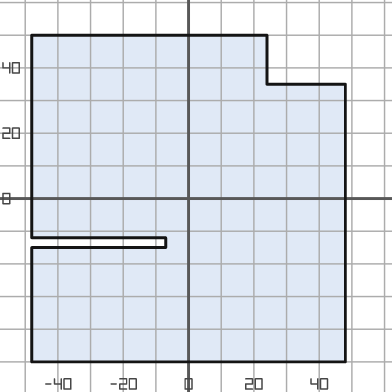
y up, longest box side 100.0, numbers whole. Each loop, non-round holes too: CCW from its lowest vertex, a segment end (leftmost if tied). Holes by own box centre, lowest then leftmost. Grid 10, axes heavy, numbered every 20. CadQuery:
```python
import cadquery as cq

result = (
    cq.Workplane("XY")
    .moveTo(-48.0, -50.0)
    .lineTo(48.0, -50.0)
    .lineTo(48.0, 35.0)
    .lineTo(24.0, 35.0)
    .lineTo(24.0, 50.0)
    .lineTo(-48.0, 50.0)
    .lineTo(-48.0, -12.0)
    .lineTo(-7.0, -12.0)
    .lineTo(-7.0, -15.0)
    .lineTo(-48.0, -15.0)
    .close()
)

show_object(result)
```